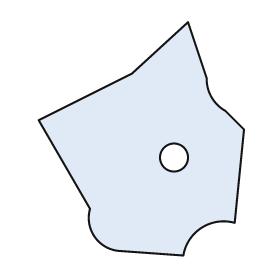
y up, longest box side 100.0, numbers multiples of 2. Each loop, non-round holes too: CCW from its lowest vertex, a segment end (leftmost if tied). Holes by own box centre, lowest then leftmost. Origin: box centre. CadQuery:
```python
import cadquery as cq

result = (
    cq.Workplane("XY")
    .moveTo(18.0, -50.0)
    .threePointArc((26.0, -38.0), (40.0, -36.0))
    .lineTo(44.0, 4.0)
    .lineTo(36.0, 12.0)
    .threePointArc((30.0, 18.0), (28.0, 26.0))
    .lineTo(20.0, 50.0)
    .lineTo(-4.0, 28.0)
    .lineTo(-44.0, 8.0)
    .lineTo(-22.0, -30.0)
    .threePointArc((-20.0, -42.0), (-10.0, -48.0))
    .close()
    .moveTo(14.0, -8.0)
    .circle(6.0)
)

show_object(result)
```